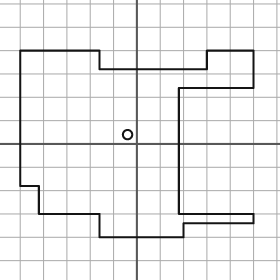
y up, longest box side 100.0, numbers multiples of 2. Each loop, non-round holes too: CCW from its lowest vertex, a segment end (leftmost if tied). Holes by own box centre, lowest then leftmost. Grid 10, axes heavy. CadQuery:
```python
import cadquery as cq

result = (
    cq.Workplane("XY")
    .moveTo(-16.0, -40.0)
    .lineTo(20.0, -40.0)
    .lineTo(20.0, -34.0)
    .lineTo(50.0, -34.0)
    .lineTo(50.0, -30.0)
    .lineTo(18.0, -30.0)
    .lineTo(18.0, 24.0)
    .lineTo(50.0, 24.0)
    .lineTo(50.0, 40.0)
    .lineTo(30.0, 40.0)
    .lineTo(30.0, 32.0)
    .lineTo(-16.0, 32.0)
    .lineTo(-16.0, 40.0)
    .lineTo(-50.0, 40.0)
    .lineTo(-50.0, -18.0)
    .lineTo(-42.0, -18.0)
    .lineTo(-42.0, -30.0)
    .lineTo(-16.0, -30.0)
    .close()
    .moveTo(-4.0, 4.0)
    .circle(2.0)
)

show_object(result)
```